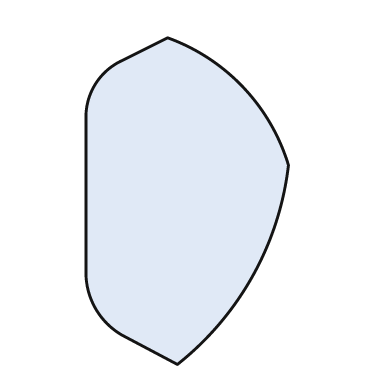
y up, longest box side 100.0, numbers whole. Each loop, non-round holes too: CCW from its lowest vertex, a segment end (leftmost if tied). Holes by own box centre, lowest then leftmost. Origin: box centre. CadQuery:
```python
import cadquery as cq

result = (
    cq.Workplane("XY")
    .moveTo(-3.0, -50.0)
    .threePointArc((20.0, -23.0), (31.0, 11.0))
    .threePointArc((17.0, 35.0), (-6.0, 50.0))
    .lineTo(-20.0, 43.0)
    .threePointArc((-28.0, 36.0), (-31.0, 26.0))
    .lineTo(-31.0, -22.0)
    .threePointArc((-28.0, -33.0), (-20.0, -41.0))
    .close()
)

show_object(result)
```